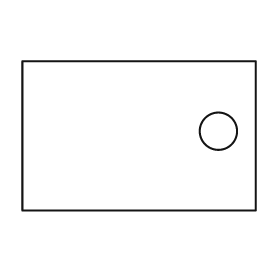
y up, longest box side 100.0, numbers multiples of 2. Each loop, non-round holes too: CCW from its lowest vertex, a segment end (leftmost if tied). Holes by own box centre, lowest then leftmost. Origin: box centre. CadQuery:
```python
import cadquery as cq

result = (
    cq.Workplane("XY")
    .moveTo(-50.0, -32.0)
    .lineTo(50.0, -32.0)
    .lineTo(50.0, 32.0)
    .lineTo(-50.0, 32.0)
    .close()
    .moveTo(34.0, 2.0)
    .circle(8.0)
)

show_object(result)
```